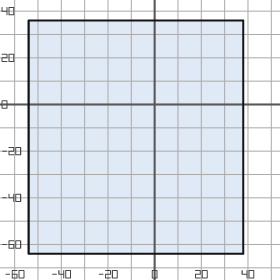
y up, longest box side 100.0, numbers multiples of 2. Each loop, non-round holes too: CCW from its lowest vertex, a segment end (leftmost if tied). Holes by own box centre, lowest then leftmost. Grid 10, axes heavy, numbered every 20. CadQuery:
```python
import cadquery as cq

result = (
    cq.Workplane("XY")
    .moveTo(-54.0, -64.0)
    .lineTo(38.0, -64.0)
    .lineTo(38.0, 36.0)
    .lineTo(-54.0, 36.0)
    .close()
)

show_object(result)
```